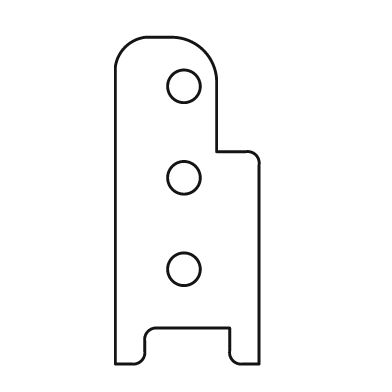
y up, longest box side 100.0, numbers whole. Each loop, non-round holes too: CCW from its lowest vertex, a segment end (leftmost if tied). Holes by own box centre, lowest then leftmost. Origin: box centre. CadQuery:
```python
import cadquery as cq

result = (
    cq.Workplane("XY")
    .moveTo(-22.0, -50.0)
    .lineTo(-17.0, -50.0)
    .threePointArc((-14.0, -49.0), (-13.0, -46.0))
    .lineTo(-13.0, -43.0)
    .threePointArc((-12.0, -40.0), (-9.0, -39.0))
    .lineTo(13.0, -39.0)
    .lineTo(13.0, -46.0)
    .threePointArc((14.0, -49.0), (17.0, -50.0))
    .lineTo(22.0, -50.0)
    .lineTo(22.0, 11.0)
    .threePointArc((21.0, 14.0), (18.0, 15.0))
    .lineTo(9.0, 15.0)
    .lineTo(9.0, 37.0)
    .threePointArc((5.0, 46.0), (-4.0, 50.0))
    .lineTo(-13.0, 50.0)
    .threePointArc((-19.0, 47.0), (-22.0, 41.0))
    .close()
    .moveTo(-1.0, -21.0)
    .circle(5.0)
    .moveTo(-1.0, 7.0)
    .circle(5.0)
    .moveTo(-1.0, 35.0)
    .circle(5.0)
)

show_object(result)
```